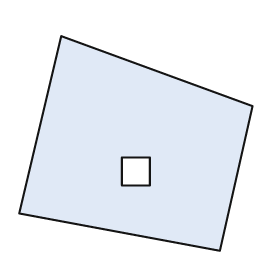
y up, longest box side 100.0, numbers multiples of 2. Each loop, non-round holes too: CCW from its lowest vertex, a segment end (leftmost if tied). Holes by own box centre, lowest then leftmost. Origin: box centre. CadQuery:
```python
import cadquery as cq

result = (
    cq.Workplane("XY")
    .moveTo(36.0, -46.0)
    .lineTo(50.0, 16.0)
    .lineTo(-32.0, 46.0)
    .lineTo(-50.0, -30.0)
    .close()
    .moveTo(-6.0, -18.0)
    .lineTo(6.0, -18.0)
    .lineTo(6.0, -6.0)
    .lineTo(-6.0, -6.0)
    .close()
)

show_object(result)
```